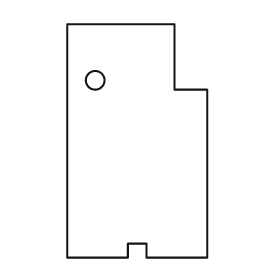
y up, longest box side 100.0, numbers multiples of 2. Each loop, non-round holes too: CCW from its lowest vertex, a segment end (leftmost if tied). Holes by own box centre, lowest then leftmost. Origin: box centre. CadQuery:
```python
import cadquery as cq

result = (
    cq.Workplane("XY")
    .moveTo(-30.0, -50.0)
    .lineTo(-4.0, -50.0)
    .lineTo(-4.0, -44.0)
    .lineTo(4.0, -44.0)
    .lineTo(4.0, -50.0)
    .lineTo(30.0, -50.0)
    .lineTo(30.0, 22.0)
    .lineTo(16.0, 22.0)
    .lineTo(16.0, 50.0)
    .lineTo(-30.0, 50.0)
    .close()
    .moveTo(-18.0, 26.0)
    .circle(4.0)
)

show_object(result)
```